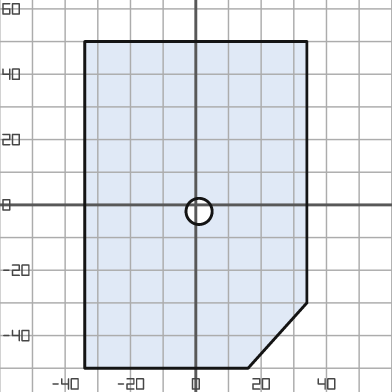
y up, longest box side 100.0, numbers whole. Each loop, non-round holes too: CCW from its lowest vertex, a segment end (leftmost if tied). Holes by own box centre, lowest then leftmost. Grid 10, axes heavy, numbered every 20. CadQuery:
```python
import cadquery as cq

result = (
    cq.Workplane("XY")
    .moveTo(-34.0, -50.0)
    .lineTo(16.0, -50.0)
    .lineTo(34.0, -30.0)
    .lineTo(34.0, 50.0)
    .lineTo(-34.0, 50.0)
    .close()
    .moveTo(1.0, -2.0)
    .circle(4.0)
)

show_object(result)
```